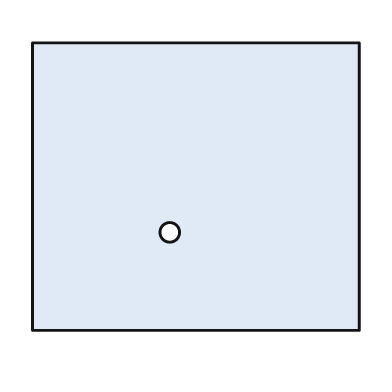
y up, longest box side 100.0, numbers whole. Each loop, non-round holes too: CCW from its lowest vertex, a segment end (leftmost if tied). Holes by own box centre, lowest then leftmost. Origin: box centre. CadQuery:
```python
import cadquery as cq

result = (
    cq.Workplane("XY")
    .moveTo(-50.0, -44.0)
    .lineTo(50.0, -44.0)
    .lineTo(50.0, 44.0)
    .lineTo(-50.0, 44.0)
    .close()
    .moveTo(-8.0, -14.0)
    .circle(3.0)
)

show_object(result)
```